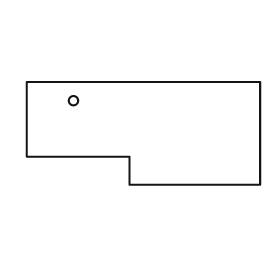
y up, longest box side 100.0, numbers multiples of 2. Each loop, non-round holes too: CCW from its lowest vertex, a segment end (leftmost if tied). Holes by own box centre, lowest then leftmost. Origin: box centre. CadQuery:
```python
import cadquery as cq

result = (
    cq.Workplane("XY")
    .moveTo(-6.0, -22.0)
    .lineTo(50.0, -22.0)
    .lineTo(50.0, 22.0)
    .lineTo(-50.0, 22.0)
    .lineTo(-50.0, -10.0)
    .lineTo(-6.0, -10.0)
    .close()
    .moveTo(-30.0, 14.0)
    .circle(2.0)
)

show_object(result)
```